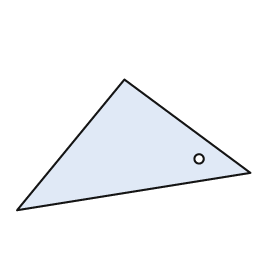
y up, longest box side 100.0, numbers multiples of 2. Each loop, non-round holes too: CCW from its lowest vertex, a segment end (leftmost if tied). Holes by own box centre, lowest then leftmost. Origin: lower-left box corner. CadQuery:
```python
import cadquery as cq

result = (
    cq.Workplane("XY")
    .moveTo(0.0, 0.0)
    .lineTo(100.0, 16.0)
    .lineTo(46.0, 56.0)
    .close()
    .moveTo(78.0, 22.0)
    .circle(2.0)
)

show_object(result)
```